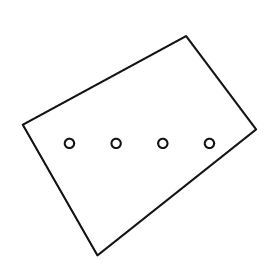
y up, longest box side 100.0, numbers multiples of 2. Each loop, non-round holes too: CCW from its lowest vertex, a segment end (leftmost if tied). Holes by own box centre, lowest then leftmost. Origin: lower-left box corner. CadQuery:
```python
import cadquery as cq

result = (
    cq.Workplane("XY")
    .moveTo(32.0, 0.0)
    .lineTo(100.0, 54.0)
    .lineTo(70.0, 94.0)
    .lineTo(0.0, 56.0)
    .close()
    .moveTo(20.0, 48.0)
    .circle(2.0)
    .moveTo(40.0, 48.0)
    .circle(2.0)
    .moveTo(60.0, 48.0)
    .circle(2.0)
    .moveTo(80.0, 48.0)
    .circle(2.0)
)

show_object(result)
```